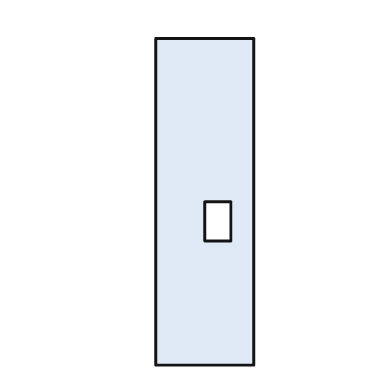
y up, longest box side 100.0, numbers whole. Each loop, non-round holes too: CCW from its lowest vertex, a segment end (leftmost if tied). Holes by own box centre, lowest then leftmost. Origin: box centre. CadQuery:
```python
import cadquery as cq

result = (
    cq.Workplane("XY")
    .moveTo(-15.0, -50.0)
    .lineTo(15.0, -50.0)
    .lineTo(15.0, 50.0)
    .lineTo(-15.0, 50.0)
    .close()
    .moveTo(0.0, -12.0)
    .lineTo(8.0, -12.0)
    .lineTo(8.0, 0.0)
    .lineTo(0.0, 0.0)
    .close()
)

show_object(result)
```